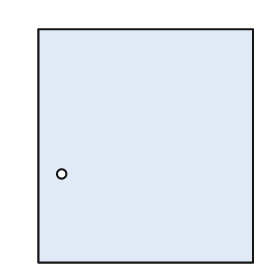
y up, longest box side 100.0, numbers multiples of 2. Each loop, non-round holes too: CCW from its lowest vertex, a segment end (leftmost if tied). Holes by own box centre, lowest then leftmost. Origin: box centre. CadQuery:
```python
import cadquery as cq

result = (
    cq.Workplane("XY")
    .moveTo(-46.0, -50.0)
    .lineTo(46.0, -50.0)
    .lineTo(46.0, 50.0)
    .lineTo(-46.0, 50.0)
    .close()
    .moveTo(-36.0, -12.0)
    .circle(2.0)
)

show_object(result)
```